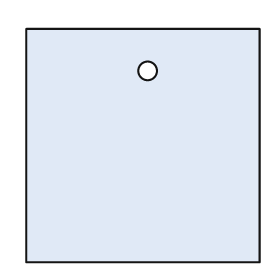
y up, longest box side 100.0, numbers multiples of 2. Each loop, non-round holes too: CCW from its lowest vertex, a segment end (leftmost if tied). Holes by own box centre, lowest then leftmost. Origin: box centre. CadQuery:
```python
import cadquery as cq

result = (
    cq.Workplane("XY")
    .moveTo(-50.0, -50.0)
    .lineTo(50.0, -50.0)
    .lineTo(50.0, 50.0)
    .lineTo(-50.0, 50.0)
    .close()
    .moveTo(2.0, 32.0)
    .circle(4.0)
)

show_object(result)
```